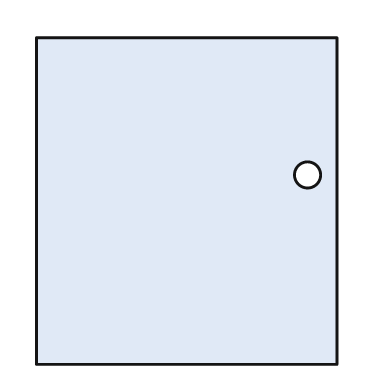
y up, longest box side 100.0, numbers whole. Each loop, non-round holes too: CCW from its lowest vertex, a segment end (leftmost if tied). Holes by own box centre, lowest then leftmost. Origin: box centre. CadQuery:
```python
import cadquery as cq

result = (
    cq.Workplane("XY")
    .moveTo(-46.0, -50.0)
    .lineTo(46.0, -50.0)
    .lineTo(46.0, 50.0)
    .lineTo(-46.0, 50.0)
    .close()
    .moveTo(37.0, 8.0)
    .circle(4.0)
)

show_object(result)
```